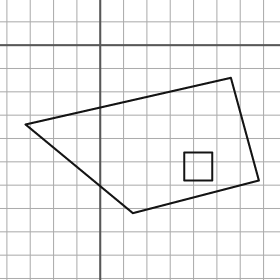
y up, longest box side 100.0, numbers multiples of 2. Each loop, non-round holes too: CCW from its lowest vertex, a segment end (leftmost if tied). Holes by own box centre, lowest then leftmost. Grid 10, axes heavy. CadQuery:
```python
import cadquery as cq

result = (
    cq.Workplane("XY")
    .moveTo(14.0, -72.0)
    .lineTo(68.0, -58.0)
    .lineTo(56.0, -14.0)
    .lineTo(-32.0, -34.0)
    .close()
    .moveTo(36.0, -58.0)
    .lineTo(48.0, -58.0)
    .lineTo(48.0, -46.0)
    .lineTo(36.0, -46.0)
    .close()
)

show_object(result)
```